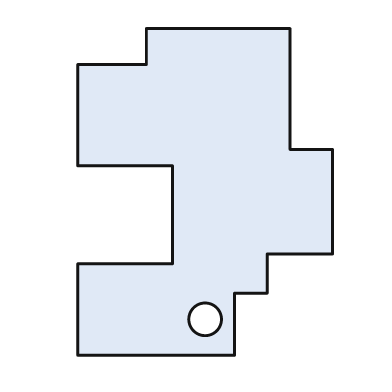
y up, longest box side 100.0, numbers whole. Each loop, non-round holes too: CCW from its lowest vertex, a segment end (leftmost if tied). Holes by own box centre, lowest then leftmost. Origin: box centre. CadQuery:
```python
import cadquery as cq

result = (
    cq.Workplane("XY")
    .moveTo(-39.0, -50.0)
    .lineTo(9.0, -50.0)
    .lineTo(9.0, -31.0)
    .lineTo(19.0, -31.0)
    .lineTo(19.0, -19.0)
    .lineTo(39.0, -19.0)
    .lineTo(39.0, 13.0)
    .lineTo(26.0, 13.0)
    .lineTo(26.0, 50.0)
    .lineTo(-18.0, 50.0)
    .lineTo(-18.0, 39.0)
    .lineTo(-39.0, 39.0)
    .lineTo(-39.0, 8.0)
    .lineTo(-10.0, 8.0)
    .lineTo(-10.0, -22.0)
    .lineTo(-39.0, -22.0)
    .close()
    .moveTo(0.0, -39.0)
    .circle(5.0)
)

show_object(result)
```